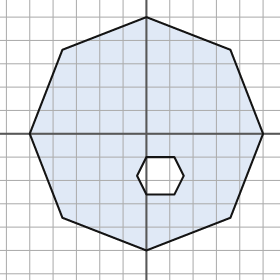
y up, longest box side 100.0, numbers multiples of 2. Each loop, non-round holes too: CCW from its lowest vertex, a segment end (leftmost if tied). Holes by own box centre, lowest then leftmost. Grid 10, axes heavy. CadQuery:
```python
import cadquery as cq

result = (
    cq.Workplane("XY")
    .moveTo(0.0, -50.0)
    .lineTo(36.0, -36.0)
    .lineTo(50.0, 0.0)
    .lineTo(36.0, 36.0)
    .lineTo(0.0, 50.0)
    .lineTo(-36.0, 36.0)
    .lineTo(-50.0, 0.0)
    .lineTo(-36.0, -36.0)
    .close()
    .moveTo(0.0, -26.0)
    .lineTo(12.0, -26.0)
    .lineTo(16.0, -18.0)
    .lineTo(12.0, -10.0)
    .lineTo(0.0, -10.0)
    .lineTo(-4.0, -18.0)
    .close()
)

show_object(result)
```